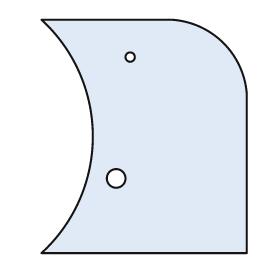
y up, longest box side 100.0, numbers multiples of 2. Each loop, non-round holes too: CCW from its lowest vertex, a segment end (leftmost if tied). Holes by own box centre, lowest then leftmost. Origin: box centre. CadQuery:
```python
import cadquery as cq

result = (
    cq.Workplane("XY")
    .moveTo(-44.0, -50.0)
    .lineTo(44.0, -50.0)
    .lineTo(44.0, 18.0)
    .threePointArc((34.0, 40.0), (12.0, 50.0))
    .lineTo(-44.0, 50.0)
    .threePointArc((-22.0, 0.0), (-44.0, -50.0))
    .close()
    .moveTo(-12.0, -18.0)
    .circle(4.0)
    .moveTo(-6.0, 34.0)
    .circle(2.0)
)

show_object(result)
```